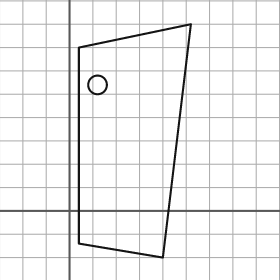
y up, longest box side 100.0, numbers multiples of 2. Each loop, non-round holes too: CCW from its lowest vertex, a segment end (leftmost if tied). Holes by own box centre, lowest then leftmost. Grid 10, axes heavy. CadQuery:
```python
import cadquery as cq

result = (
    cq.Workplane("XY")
    .moveTo(40.0, -20.0)
    .lineTo(52.0, 80.0)
    .lineTo(4.0, 70.0)
    .lineTo(4.0, -14.0)
    .close()
    .moveTo(12.0, 54.0)
    .circle(4.0)
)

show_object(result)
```